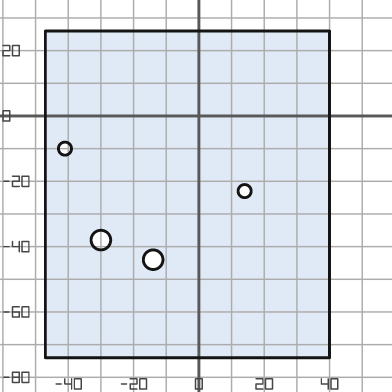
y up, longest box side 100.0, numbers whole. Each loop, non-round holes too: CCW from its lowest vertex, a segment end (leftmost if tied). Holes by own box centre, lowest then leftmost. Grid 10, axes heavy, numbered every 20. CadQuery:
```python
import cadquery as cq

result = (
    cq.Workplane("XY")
    .moveTo(-47.0, -74.0)
    .lineTo(40.0, -74.0)
    .lineTo(40.0, 26.0)
    .lineTo(-47.0, 26.0)
    .close()
    .moveTo(-14.0, -44.0)
    .circle(3.0)
    .moveTo(-30.0, -38.0)
    .circle(3.0)
    .moveTo(14.0, -23.0)
    .circle(2.0)
    .moveTo(-41.0, -10.0)
    .circle(2.0)
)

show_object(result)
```